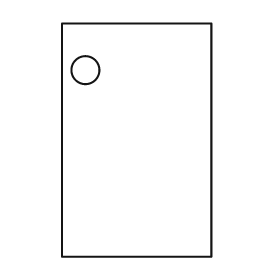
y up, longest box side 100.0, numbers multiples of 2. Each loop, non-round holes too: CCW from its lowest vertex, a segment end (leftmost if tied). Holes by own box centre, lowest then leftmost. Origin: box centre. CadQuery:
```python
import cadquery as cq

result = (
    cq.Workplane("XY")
    .moveTo(-32.0, -50.0)
    .lineTo(32.0, -50.0)
    .lineTo(32.0, 50.0)
    .lineTo(-32.0, 50.0)
    .close()
    .moveTo(-22.0, 30.0)
    .circle(6.0)
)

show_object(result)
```